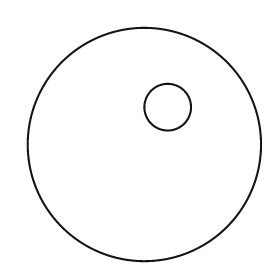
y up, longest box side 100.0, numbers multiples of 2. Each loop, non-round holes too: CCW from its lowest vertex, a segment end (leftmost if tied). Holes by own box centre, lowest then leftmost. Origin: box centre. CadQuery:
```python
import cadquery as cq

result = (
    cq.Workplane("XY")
    .moveTo(0.0, 0.0)
    .circle(50.0)
    .moveTo(10.0, 16.0)
    .circle(10.0)
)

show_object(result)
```